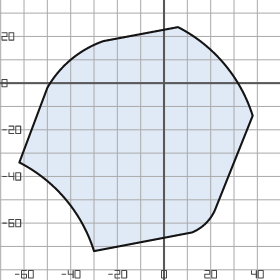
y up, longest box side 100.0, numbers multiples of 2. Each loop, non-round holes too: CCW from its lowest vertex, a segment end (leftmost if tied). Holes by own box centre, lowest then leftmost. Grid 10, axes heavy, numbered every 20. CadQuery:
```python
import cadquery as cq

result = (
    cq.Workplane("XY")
    .moveTo(-30.0, -72.0)
    .lineTo(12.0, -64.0)
    .threePointArc((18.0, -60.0), (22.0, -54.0))
    .lineTo(38.0, -14.0)
    .threePointArc((26.0, 8.0), (6.0, 24.0))
    .lineTo(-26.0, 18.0)
    .threePointArc((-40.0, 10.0), (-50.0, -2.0))
    .lineTo(-62.0, -34.0)
    .threePointArc((-42.0, -50.0), (-30.0, -72.0))
    .close()
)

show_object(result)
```